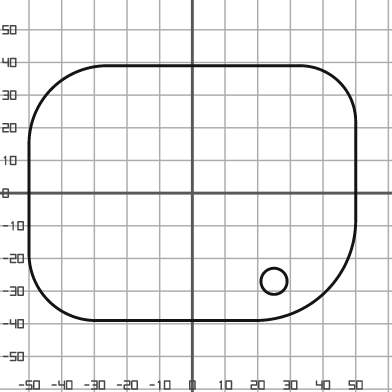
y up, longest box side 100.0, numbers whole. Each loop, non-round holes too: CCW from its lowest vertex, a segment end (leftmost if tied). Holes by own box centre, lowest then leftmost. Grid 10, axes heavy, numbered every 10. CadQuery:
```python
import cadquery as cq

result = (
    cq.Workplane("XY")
    .moveTo(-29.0, -39.0)
    .lineTo(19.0, -39.0)
    .threePointArc((41.0, -30.0), (50.0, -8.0))
    .lineTo(50.0, 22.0)
    .threePointArc((45.0, 34.0), (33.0, 39.0))
    .lineTo(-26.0, 39.0)
    .threePointArc((-43.0, 32.0), (-50.0, 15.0))
    .lineTo(-50.0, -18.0)
    .threePointArc((-44.0, -33.0), (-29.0, -39.0))
    .close()
    .moveTo(25.0, -27.0)
    .circle(4.0)
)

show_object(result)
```